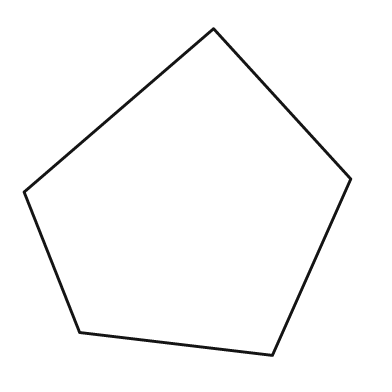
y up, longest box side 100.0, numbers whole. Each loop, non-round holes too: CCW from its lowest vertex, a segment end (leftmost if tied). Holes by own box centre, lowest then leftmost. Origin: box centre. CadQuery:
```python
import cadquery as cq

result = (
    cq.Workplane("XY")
    .moveTo(26.0, -50.0)
    .lineTo(50.0, 4.0)
    .lineTo(8.0, 50.0)
    .lineTo(-50.0, 0.0)
    .lineTo(-33.0, -43.0)
    .close()
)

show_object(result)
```